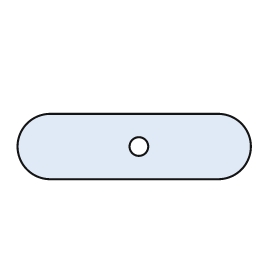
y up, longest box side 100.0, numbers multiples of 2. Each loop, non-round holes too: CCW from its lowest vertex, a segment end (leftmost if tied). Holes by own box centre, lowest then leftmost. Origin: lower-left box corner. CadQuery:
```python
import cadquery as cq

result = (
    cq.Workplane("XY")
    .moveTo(14.0, 0.0)
    .lineTo(86.0, 0.0)
    .threePointArc((100.0, 14.0), (86.0, 28.0))
    .lineTo(14.0, 28.0)
    .threePointArc((0.0, 14.0), (14.0, 0.0))
    .close()
    .moveTo(52.0, 14.0)
    .circle(4.0)
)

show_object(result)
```